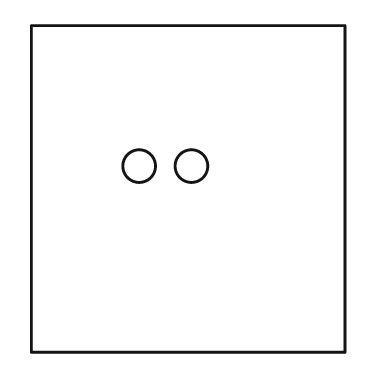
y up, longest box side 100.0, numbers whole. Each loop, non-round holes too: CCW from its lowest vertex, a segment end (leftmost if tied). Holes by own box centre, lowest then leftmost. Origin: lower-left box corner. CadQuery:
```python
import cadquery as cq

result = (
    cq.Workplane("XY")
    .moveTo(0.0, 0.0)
    .lineTo(96.0, 0.0)
    .lineTo(96.0, 100.0)
    .lineTo(0.0, 100.0)
    .close()
    .moveTo(33.0, 57.0)
    .circle(5.0)
    .moveTo(49.0, 57.0)
    .circle(5.0)
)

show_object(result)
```